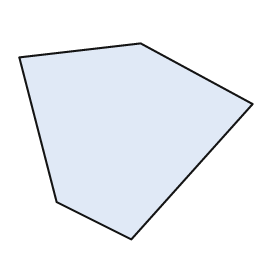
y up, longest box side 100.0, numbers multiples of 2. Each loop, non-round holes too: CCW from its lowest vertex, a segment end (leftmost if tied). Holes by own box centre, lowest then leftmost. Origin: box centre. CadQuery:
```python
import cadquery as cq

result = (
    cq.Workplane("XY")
    .moveTo(-2.0, -42.0)
    .lineTo(50.0, 16.0)
    .lineTo(2.0, 42.0)
    .lineTo(-50.0, 36.0)
    .lineTo(-34.0, -26.0)
    .close()
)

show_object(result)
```